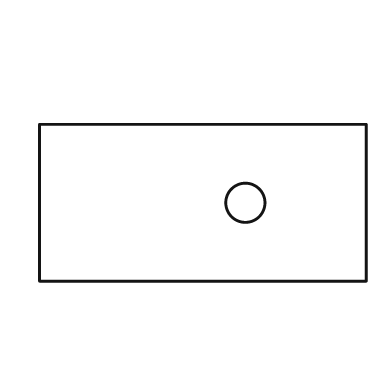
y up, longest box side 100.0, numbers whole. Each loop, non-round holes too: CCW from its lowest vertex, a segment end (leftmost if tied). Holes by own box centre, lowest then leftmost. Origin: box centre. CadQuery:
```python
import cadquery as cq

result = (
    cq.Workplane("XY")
    .moveTo(-50.0, -24.0)
    .lineTo(50.0, -24.0)
    .lineTo(50.0, 24.0)
    .lineTo(-50.0, 24.0)
    .close()
    .moveTo(13.0, 0.0)
    .circle(6.0)
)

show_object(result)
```